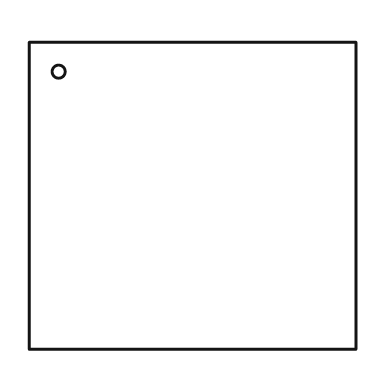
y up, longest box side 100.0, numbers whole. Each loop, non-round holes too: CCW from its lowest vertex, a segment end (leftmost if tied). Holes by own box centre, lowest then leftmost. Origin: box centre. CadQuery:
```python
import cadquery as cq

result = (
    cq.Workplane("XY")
    .moveTo(-50.0, -47.0)
    .lineTo(50.0, -47.0)
    .lineTo(50.0, 47.0)
    .lineTo(-50.0, 47.0)
    .close()
    .moveTo(-41.0, 38.0)
    .circle(2.0)
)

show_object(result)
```